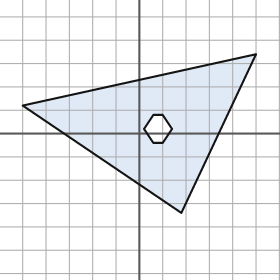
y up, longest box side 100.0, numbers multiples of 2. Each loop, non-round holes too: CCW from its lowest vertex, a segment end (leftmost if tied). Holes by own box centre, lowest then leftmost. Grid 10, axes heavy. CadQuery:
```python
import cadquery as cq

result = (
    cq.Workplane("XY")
    .moveTo(18.0, -34.0)
    .lineTo(50.0, 34.0)
    .lineTo(-50.0, 12.0)
    .close()
    .moveTo(6.0, -4.0)
    .lineTo(10.0, -4.0)
    .lineTo(14.0, 2.0)
    .lineTo(10.0, 8.0)
    .lineTo(6.0, 8.0)
    .lineTo(2.0, 2.0)
    .close()
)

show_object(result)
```